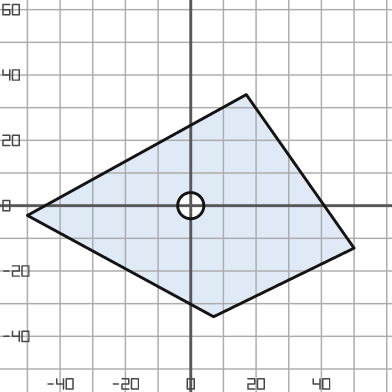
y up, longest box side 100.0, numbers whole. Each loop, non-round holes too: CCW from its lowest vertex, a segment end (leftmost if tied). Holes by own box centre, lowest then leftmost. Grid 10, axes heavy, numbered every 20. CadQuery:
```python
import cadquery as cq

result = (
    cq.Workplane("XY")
    .moveTo(7.0, -34.0)
    .lineTo(50.0, -13.0)
    .lineTo(17.0, 34.0)
    .lineTo(-50.0, -3.0)
    .close()
    .moveTo(0.0, 0.0)
    .circle(4.0)
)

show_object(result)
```